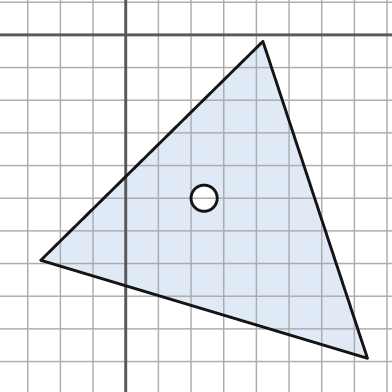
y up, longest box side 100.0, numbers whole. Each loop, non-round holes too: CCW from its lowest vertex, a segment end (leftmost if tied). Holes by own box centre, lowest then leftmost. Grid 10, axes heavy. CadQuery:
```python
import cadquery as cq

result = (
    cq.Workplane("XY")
    .moveTo(74.0, -99.0)
    .lineTo(42.0, -2.0)
    .lineTo(-26.0, -69.0)
    .close()
    .moveTo(24.0, -50.0)
    .circle(4.0)
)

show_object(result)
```